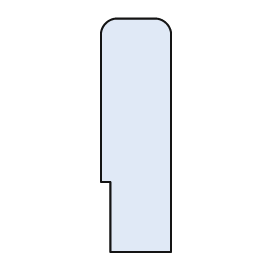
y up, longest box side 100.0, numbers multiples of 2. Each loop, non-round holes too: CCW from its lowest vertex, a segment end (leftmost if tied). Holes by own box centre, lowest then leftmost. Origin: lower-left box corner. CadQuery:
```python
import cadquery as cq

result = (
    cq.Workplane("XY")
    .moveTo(4.0, 0.0)
    .lineTo(30.0, 0.0)
    .lineTo(30.0, 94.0)
    .threePointArc((28.0, 98.0), (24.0, 100.0))
    .lineTo(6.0, 100.0)
    .threePointArc((2.0, 98.0), (0.0, 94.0))
    .lineTo(0.0, 30.0)
    .lineTo(4.0, 30.0)
    .close()
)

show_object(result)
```